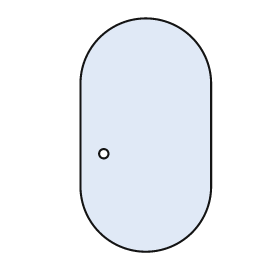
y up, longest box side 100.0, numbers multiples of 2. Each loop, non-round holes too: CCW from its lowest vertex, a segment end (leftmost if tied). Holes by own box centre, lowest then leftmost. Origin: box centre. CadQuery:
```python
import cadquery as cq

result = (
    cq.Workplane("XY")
    .moveTo(-28.0, -22.0)
    .threePointArc((0.0, -50.0), (28.0, -22.0))
    .lineTo(28.0, 22.0)
    .threePointArc((0.0, 50.0), (-28.0, 22.0))
    .close()
    .moveTo(-18.0, -8.0)
    .circle(2.0)
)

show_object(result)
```